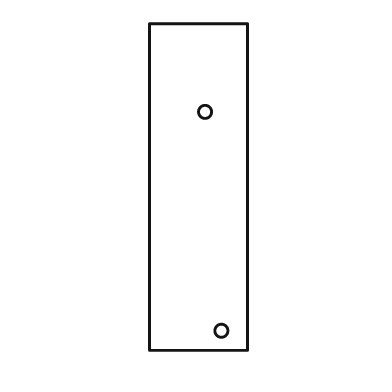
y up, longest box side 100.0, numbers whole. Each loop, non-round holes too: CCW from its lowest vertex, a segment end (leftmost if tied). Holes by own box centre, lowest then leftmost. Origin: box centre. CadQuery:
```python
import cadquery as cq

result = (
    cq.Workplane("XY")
    .moveTo(-15.0, -50.0)
    .lineTo(15.0, -50.0)
    .lineTo(15.0, 50.0)
    .lineTo(-15.0, 50.0)
    .close()
    .moveTo(7.0, -44.0)
    .circle(2.0)
    .moveTo(2.0, 23.0)
    .circle(2.0)
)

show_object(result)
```